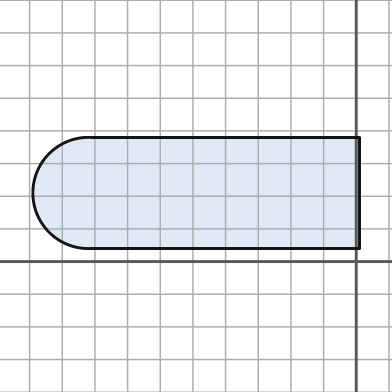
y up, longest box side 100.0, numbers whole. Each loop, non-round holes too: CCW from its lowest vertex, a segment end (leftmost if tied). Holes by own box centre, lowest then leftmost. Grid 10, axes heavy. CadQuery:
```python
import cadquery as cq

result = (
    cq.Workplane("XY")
    .moveTo(-81.0, 4.0)
    .lineTo(1.0, 4.0)
    .lineTo(1.0, 38.0)
    .lineTo(-81.0, 38.0)
    .threePointArc((-99.0, 21.0), (-81.0, 4.0))
    .close()
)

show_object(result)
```